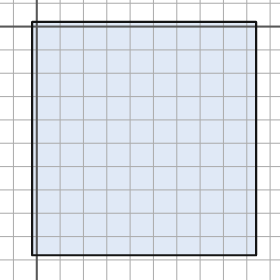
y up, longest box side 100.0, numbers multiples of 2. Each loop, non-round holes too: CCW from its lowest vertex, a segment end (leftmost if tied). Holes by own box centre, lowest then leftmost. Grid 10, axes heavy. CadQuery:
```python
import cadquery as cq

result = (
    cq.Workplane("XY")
    .moveTo(-2.0, -98.0)
    .lineTo(94.0, -98.0)
    .lineTo(94.0, 2.0)
    .lineTo(-2.0, 2.0)
    .close()
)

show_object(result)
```